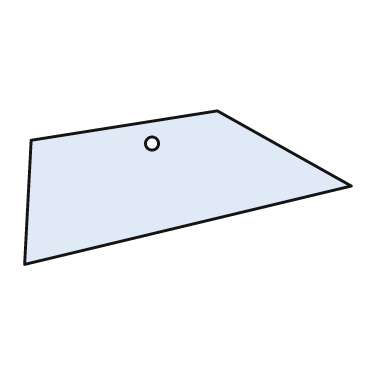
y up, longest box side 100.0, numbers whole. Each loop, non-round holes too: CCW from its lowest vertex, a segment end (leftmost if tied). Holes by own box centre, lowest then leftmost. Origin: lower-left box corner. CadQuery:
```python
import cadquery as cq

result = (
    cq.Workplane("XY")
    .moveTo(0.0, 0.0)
    .lineTo(100.0, 24.0)
    .lineTo(59.0, 47.0)
    .lineTo(2.0, 38.0)
    .close()
    .moveTo(39.0, 37.0)
    .circle(2.0)
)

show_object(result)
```